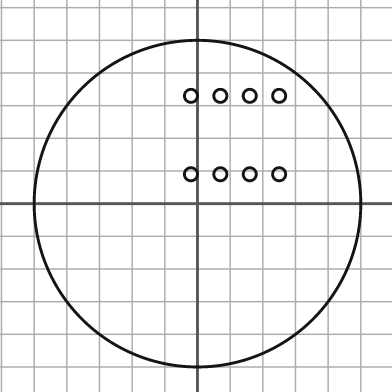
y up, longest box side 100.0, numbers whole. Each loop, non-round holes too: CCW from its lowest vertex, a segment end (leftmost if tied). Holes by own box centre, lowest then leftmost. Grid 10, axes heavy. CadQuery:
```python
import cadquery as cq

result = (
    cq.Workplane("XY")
    .moveTo(0.0, 0.0)
    .circle(50.0)
    .moveTo(-2.0, 9.0)
    .circle(2.0)
    .moveTo(7.0, 9.0)
    .circle(2.0)
    .moveTo(16.0, 9.0)
    .circle(2.0)
    .moveTo(25.0, 9.0)
    .circle(2.0)
    .moveTo(-2.0, 33.0)
    .circle(2.0)
    .moveTo(7.0, 33.0)
    .circle(2.0)
    .moveTo(16.0, 33.0)
    .circle(2.0)
    .moveTo(25.0, 33.0)
    .circle(2.0)
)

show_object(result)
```